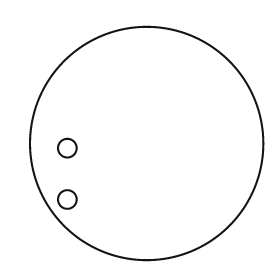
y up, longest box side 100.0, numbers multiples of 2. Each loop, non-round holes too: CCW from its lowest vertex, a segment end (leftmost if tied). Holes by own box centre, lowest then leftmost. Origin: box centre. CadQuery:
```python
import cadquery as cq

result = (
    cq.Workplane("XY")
    .moveTo(0.0, 0.0)
    .circle(50.0)
    .moveTo(-34.0, -24.0)
    .circle(4.0)
    .moveTo(-34.0, -2.0)
    .circle(4.0)
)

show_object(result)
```